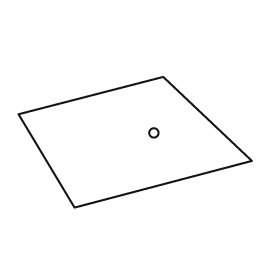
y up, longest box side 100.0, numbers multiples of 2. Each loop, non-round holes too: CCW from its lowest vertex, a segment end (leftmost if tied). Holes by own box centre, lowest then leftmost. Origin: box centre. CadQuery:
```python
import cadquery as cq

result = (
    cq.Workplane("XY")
    .moveTo(-26.0, -28.0)
    .lineTo(50.0, -8.0)
    .lineTo(12.0, 28.0)
    .lineTo(-50.0, 12.0)
    .close()
    .moveTo(8.0, 4.0)
    .circle(2.0)
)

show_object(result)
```